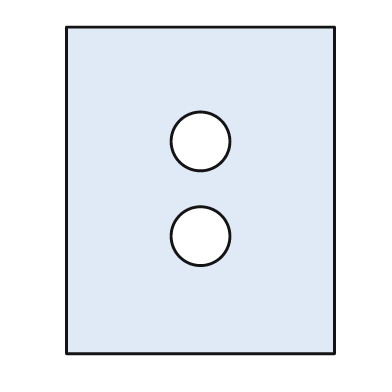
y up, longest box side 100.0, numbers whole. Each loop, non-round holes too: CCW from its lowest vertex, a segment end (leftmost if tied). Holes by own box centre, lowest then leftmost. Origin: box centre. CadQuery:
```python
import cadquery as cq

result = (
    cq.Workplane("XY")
    .moveTo(-41.0, -50.0)
    .lineTo(41.0, -50.0)
    .lineTo(41.0, 50.0)
    .lineTo(-41.0, 50.0)
    .close()
    .moveTo(0.0, -14.0)
    .circle(9.0)
    .moveTo(0.0, 15.0)
    .circle(9.0)
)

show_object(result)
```